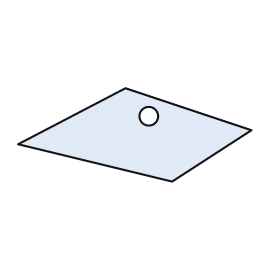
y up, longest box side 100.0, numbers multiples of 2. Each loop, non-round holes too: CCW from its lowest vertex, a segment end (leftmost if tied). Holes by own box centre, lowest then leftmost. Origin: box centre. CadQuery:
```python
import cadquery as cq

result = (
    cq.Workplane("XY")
    .moveTo(16.0, -20.0)
    .lineTo(50.0, 2.0)
    .lineTo(-4.0, 20.0)
    .lineTo(-50.0, -4.0)
    .close()
    .moveTo(6.0, 8.0)
    .circle(4.0)
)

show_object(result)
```